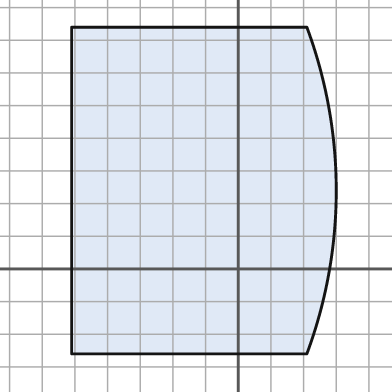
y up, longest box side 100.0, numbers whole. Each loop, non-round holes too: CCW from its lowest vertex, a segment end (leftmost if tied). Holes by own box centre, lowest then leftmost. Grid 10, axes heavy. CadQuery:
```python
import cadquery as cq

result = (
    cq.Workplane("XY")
    .moveTo(-51.0, -26.0)
    .lineTo(21.0, -26.0)
    .threePointArc((30.0, 24.0), (21.0, 74.0))
    .lineTo(-51.0, 74.0)
    .close()
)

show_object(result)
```